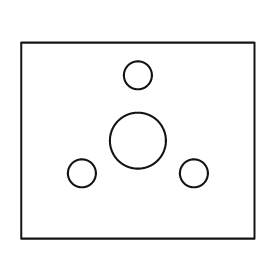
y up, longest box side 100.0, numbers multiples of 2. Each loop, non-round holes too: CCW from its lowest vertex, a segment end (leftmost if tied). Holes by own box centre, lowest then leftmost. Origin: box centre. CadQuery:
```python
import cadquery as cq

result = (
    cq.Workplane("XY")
    .moveTo(-50.0, -42.0)
    .lineTo(50.0, -42.0)
    .lineTo(50.0, 42.0)
    .lineTo(-50.0, 42.0)
    .close()
    .moveTo(-24.0, -14.0)
    .circle(6.0)
    .moveTo(24.0, -14.0)
    .circle(6.0)
    .moveTo(0.0, 0.0)
    .circle(12.0)
    .moveTo(0.0, 28.0)
    .circle(6.0)
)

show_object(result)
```